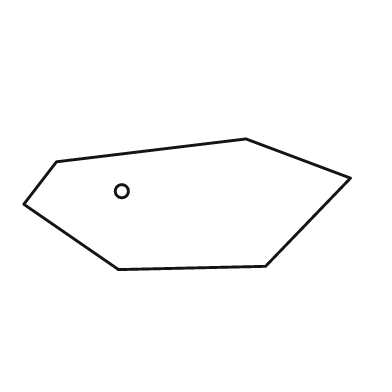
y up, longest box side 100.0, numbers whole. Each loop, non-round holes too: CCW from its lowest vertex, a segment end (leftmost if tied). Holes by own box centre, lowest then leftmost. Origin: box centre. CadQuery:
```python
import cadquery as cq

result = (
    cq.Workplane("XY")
    .moveTo(-21.0, -20.0)
    .lineTo(24.0, -19.0)
    .lineTo(50.0, 8.0)
    .lineTo(18.0, 20.0)
    .lineTo(-40.0, 13.0)
    .lineTo(-50.0, 0.0)
    .close()
    .moveTo(-20.0, 4.0)
    .circle(2.0)
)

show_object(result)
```